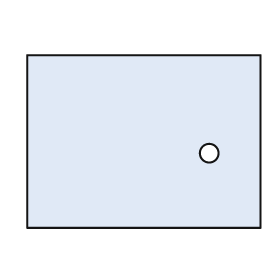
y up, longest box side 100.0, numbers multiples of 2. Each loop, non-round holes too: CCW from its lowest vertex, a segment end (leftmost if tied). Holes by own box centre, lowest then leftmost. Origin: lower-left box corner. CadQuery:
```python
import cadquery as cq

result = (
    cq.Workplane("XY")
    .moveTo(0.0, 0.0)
    .lineTo(100.0, 0.0)
    .lineTo(100.0, 74.0)
    .lineTo(0.0, 74.0)
    .close()
    .moveTo(78.0, 32.0)
    .circle(4.0)
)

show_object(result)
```